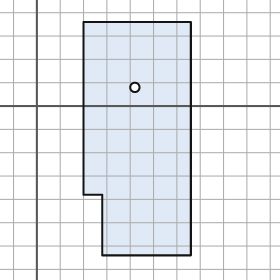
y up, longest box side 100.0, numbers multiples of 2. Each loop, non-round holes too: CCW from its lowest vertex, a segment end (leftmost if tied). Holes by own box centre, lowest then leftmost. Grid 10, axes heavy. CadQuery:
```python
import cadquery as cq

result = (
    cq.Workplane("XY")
    .moveTo(28.0, -64.0)
    .lineTo(66.0, -64.0)
    .lineTo(66.0, 36.0)
    .lineTo(20.0, 36.0)
    .lineTo(20.0, -38.0)
    .lineTo(28.0, -38.0)
    .close()
    .moveTo(42.0, 8.0)
    .circle(2.0)
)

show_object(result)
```